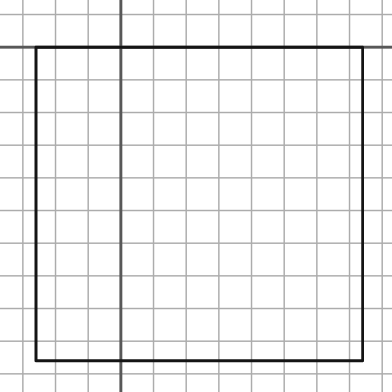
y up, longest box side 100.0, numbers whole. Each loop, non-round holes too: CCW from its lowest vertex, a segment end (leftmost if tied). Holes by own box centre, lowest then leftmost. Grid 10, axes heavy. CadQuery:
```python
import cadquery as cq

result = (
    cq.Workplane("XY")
    .moveTo(-26.0, -96.0)
    .lineTo(74.0, -96.0)
    .lineTo(74.0, 0.0)
    .lineTo(-26.0, 0.0)
    .close()
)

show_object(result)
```